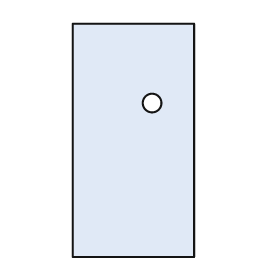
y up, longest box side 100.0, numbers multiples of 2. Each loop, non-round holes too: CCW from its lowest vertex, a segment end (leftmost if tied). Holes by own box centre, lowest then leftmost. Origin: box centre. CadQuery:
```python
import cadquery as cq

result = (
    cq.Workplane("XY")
    .moveTo(-26.0, -50.0)
    .lineTo(26.0, -50.0)
    .lineTo(26.0, 50.0)
    .lineTo(-26.0, 50.0)
    .close()
    .moveTo(8.0, 16.0)
    .circle(4.0)
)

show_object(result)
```